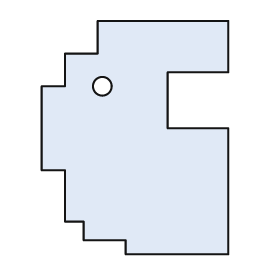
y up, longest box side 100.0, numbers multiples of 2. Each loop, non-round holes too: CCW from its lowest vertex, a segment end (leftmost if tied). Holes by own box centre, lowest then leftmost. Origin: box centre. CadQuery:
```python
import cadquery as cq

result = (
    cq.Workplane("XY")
    .moveTo(-4.0, -50.0)
    .lineTo(40.0, -50.0)
    .lineTo(40.0, 4.0)
    .lineTo(14.0, 4.0)
    .lineTo(14.0, 28.0)
    .lineTo(40.0, 28.0)
    .lineTo(40.0, 50.0)
    .lineTo(-16.0, 50.0)
    .lineTo(-16.0, 36.0)
    .lineTo(-30.0, 36.0)
    .lineTo(-30.0, 22.0)
    .lineTo(-40.0, 22.0)
    .lineTo(-40.0, -14.0)
    .lineTo(-30.0, -14.0)
    .lineTo(-30.0, -36.0)
    .lineTo(-22.0, -36.0)
    .lineTo(-22.0, -44.0)
    .lineTo(-4.0, -44.0)
    .close()
    .moveTo(-14.0, 22.0)
    .circle(4.0)
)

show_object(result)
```